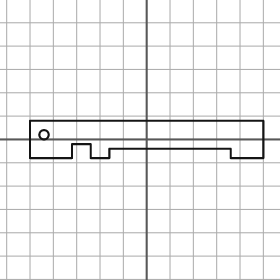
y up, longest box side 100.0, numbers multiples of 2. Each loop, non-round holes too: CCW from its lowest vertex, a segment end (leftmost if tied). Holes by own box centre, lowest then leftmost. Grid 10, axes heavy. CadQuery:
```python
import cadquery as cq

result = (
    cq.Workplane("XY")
    .moveTo(-50.0, -8.0)
    .lineTo(-32.0, -8.0)
    .lineTo(-32.0, -2.0)
    .lineTo(-24.0, -2.0)
    .lineTo(-24.0, -8.0)
    .lineTo(-16.0, -8.0)
    .lineTo(-16.0, -4.0)
    .lineTo(36.0, -4.0)
    .lineTo(36.0, -8.0)
    .lineTo(50.0, -8.0)
    .lineTo(50.0, 8.0)
    .lineTo(-50.0, 8.0)
    .close()
    .moveTo(-44.0, 2.0)
    .circle(2.0)
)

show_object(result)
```